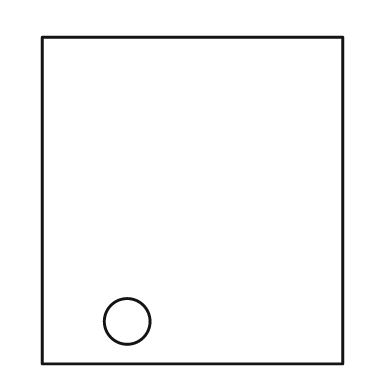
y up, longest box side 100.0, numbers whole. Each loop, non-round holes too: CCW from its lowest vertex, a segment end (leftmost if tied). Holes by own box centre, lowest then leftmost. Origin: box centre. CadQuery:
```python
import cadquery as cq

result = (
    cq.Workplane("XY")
    .moveTo(-46.0, -50.0)
    .lineTo(46.0, -50.0)
    .lineTo(46.0, 50.0)
    .lineTo(-46.0, 50.0)
    .close()
    .moveTo(-20.0, -37.0)
    .circle(7.0)
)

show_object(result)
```